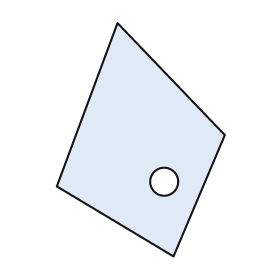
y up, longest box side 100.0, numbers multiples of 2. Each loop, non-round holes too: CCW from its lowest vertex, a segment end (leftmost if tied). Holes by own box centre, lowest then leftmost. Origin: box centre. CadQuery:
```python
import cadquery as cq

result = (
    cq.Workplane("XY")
    .moveTo(14.0, -50.0)
    .lineTo(36.0, 2.0)
    .lineTo(-10.0, 50.0)
    .lineTo(-36.0, -20.0)
    .close()
    .moveTo(10.0, -18.0)
    .circle(6.0)
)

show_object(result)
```